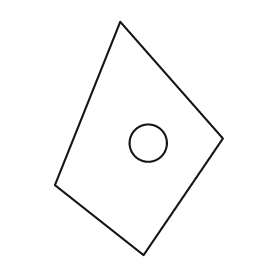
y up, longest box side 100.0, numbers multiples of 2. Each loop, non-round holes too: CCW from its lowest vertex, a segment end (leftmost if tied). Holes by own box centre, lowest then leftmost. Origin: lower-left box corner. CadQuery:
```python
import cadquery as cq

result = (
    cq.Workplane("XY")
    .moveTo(38.0, 0.0)
    .lineTo(72.0, 50.0)
    .lineTo(28.0, 100.0)
    .lineTo(0.0, 30.0)
    .close()
    .moveTo(40.0, 48.0)
    .circle(8.0)
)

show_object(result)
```